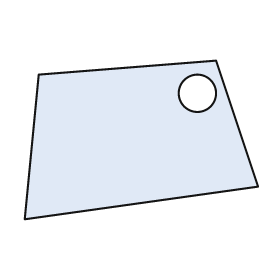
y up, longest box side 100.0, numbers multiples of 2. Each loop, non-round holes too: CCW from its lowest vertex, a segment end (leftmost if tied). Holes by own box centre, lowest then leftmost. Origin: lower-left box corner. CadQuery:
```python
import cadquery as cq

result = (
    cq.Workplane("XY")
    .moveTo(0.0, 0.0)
    .lineTo(100.0, 14.0)
    .lineTo(82.0, 68.0)
    .lineTo(6.0, 62.0)
    .close()
    .moveTo(74.0, 54.0)
    .circle(8.0)
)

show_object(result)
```